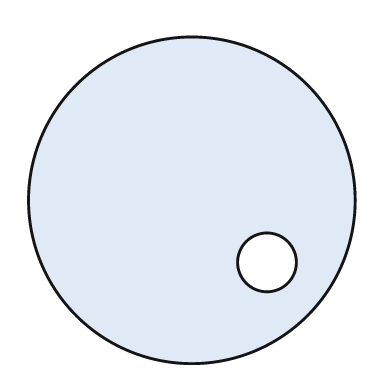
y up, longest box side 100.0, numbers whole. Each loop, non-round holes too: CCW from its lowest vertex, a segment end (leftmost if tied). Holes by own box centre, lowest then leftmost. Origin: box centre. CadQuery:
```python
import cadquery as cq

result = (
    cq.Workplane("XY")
    .moveTo(0.0, 0.0)
    .circle(50.0)
    .moveTo(23.0, -19.0)
    .circle(9.0)
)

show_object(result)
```